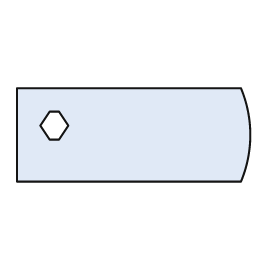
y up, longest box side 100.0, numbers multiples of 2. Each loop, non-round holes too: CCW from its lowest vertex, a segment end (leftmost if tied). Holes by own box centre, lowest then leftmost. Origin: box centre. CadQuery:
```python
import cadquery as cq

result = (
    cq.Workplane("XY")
    .moveTo(-50.0, -20.0)
    .lineTo(46.0, -20.0)
    .threePointArc((50.0, 0.0), (46.0, 20.0))
    .lineTo(-50.0, 20.0)
    .close()
    .moveTo(-36.0, -2.0)
    .lineTo(-32.0, -2.0)
    .lineTo(-28.0, 4.0)
    .lineTo(-32.0, 10.0)
    .lineTo(-36.0, 10.0)
    .lineTo(-40.0, 4.0)
    .close()
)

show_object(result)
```